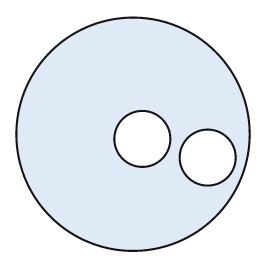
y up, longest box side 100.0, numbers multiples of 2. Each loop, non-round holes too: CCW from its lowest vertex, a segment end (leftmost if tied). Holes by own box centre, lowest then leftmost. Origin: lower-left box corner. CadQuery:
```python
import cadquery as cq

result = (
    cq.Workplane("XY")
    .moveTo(50.0, 50.0)
    .circle(50.0)
    .moveTo(82.0, 40.0)
    .circle(12.0)
    .moveTo(54.0, 48.0)
    .circle(12.0)
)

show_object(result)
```